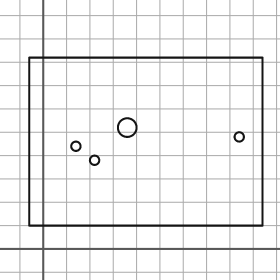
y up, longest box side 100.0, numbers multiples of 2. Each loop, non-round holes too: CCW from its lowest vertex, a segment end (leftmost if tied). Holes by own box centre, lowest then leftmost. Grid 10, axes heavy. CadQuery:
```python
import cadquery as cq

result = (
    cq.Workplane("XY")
    .moveTo(-6.0, 10.0)
    .lineTo(94.0, 10.0)
    .lineTo(94.0, 82.0)
    .lineTo(-6.0, 82.0)
    .close()
    .moveTo(22.0, 38.0)
    .circle(2.0)
    .moveTo(14.0, 44.0)
    .circle(2.0)
    .moveTo(84.0, 48.0)
    .circle(2.0)
    .moveTo(36.0, 52.0)
    .circle(4.0)
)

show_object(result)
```